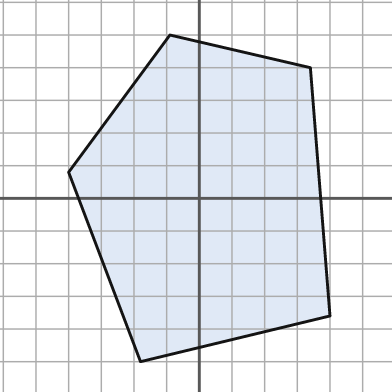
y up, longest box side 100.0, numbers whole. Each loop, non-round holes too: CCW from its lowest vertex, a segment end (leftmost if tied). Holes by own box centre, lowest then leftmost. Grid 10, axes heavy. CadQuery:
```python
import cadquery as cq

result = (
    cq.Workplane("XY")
    .moveTo(-18.0, -50.0)
    .lineTo(40.0, -36.0)
    .lineTo(34.0, 40.0)
    .lineTo(-9.0, 50.0)
    .lineTo(-40.0, 8.0)
    .close()
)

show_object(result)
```